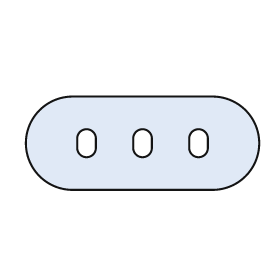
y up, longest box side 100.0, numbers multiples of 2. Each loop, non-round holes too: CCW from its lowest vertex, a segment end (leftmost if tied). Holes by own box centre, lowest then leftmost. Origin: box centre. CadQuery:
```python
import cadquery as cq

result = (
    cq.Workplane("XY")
    .moveTo(-30.0, -20.0)
    .lineTo(30.0, -20.0)
    .threePointArc((50.0, 0.0), (30.0, 20.0))
    .lineTo(-30.0, 20.0)
    .threePointArc((-50.0, 0.0), (-30.0, -20.0))
    .close()
    .moveTo(-28.0, -2.0)
    .threePointArc((-24.0, -6.0), (-20.0, -2.0))
    .lineTo(-20.0, 2.0)
    .threePointArc((-24.0, 6.0), (-28.0, 2.0))
    .close()
    .moveTo(-4.0, -2.0)
    .threePointArc((0.0, -6.0), (4.0, -2.0))
    .lineTo(4.0, 2.0)
    .threePointArc((0.0, 6.0), (-4.0, 2.0))
    .close()
    .moveTo(20.0, -2.0)
    .threePointArc((24.0, -6.0), (28.0, -2.0))
    .lineTo(28.0, 2.0)
    .threePointArc((24.0, 6.0), (20.0, 2.0))
    .close()
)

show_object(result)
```